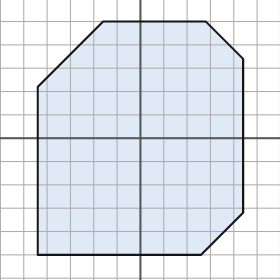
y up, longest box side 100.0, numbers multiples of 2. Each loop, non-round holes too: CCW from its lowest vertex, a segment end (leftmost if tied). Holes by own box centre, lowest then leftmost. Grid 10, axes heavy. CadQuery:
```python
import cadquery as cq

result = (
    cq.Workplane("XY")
    .moveTo(-44.0, -50.0)
    .lineTo(26.0, -50.0)
    .lineTo(44.0, -32.0)
    .lineTo(44.0, 34.0)
    .lineTo(28.0, 50.0)
    .lineTo(-16.0, 50.0)
    .lineTo(-44.0, 22.0)
    .close()
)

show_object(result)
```